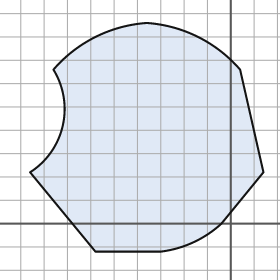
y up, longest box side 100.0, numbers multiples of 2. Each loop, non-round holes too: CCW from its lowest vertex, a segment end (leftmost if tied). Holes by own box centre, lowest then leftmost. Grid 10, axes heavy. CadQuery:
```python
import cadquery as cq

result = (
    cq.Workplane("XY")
    .moveTo(-58.0, -12.0)
    .lineTo(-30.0, -12.0)
    .threePointArc((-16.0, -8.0), (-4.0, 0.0))
    .lineTo(14.0, 22.0)
    .lineTo(4.0, 66.0)
    .threePointArc((-14.0, 80.0), (-36.0, 86.0))
    .threePointArc((-58.0, 80.0), (-76.0, 66.0))
    .threePointArc((-72.0, 42.0), (-86.0, 22.0))
    .close()
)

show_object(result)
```